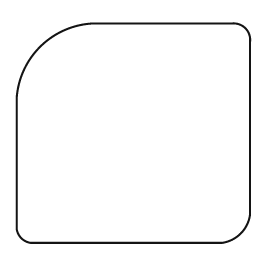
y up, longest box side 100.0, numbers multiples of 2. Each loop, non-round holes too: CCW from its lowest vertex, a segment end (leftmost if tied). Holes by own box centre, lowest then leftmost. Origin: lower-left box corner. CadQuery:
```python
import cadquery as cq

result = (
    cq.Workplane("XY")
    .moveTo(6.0, 0.0)
    .lineTo(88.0, 0.0)
    .threePointArc((96.0, 4.0), (100.0, 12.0))
    .lineTo(100.0, 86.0)
    .threePointArc((98.0, 92.0), (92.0, 94.0))
    .lineTo(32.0, 94.0)
    .threePointArc((10.0, 84.0), (0.0, 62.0))
    .lineTo(0.0, 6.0)
    .threePointArc((2.0, 2.0), (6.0, 0.0))
    .close()
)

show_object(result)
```